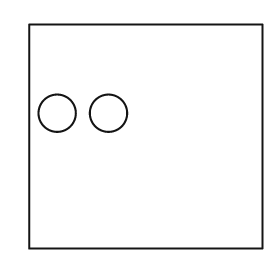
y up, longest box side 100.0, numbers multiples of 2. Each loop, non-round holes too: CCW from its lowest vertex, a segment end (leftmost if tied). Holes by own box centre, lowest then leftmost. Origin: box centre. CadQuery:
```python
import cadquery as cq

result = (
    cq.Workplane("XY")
    .moveTo(-50.0, -48.0)
    .lineTo(50.0, -48.0)
    .lineTo(50.0, 48.0)
    .lineTo(-50.0, 48.0)
    .close()
    .moveTo(-38.0, 10.0)
    .circle(8.0)
    .moveTo(-16.0, 10.0)
    .circle(8.0)
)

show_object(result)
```